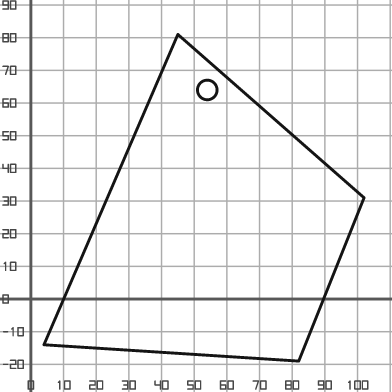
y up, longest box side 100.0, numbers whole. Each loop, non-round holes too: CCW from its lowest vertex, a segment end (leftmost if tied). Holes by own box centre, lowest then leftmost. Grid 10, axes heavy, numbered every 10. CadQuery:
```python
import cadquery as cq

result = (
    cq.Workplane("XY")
    .moveTo(82.0, -19.0)
    .lineTo(102.0, 31.0)
    .lineTo(45.0, 81.0)
    .lineTo(4.0, -14.0)
    .close()
    .moveTo(54.0, 64.0)
    .circle(3.0)
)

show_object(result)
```